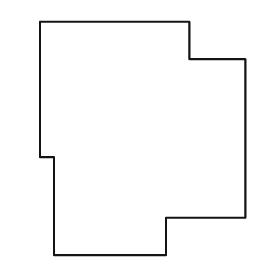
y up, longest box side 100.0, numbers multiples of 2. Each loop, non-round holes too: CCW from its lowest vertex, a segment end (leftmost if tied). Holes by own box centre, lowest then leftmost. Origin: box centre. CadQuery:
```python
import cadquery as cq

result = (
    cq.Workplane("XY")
    .moveTo(-38.0, -50.0)
    .lineTo(10.0, -50.0)
    .lineTo(10.0, -34.0)
    .lineTo(44.0, -34.0)
    .lineTo(44.0, 34.0)
    .lineTo(20.0, 34.0)
    .lineTo(20.0, 50.0)
    .lineTo(-44.0, 50.0)
    .lineTo(-44.0, -8.0)
    .lineTo(-38.0, -8.0)
    .close()
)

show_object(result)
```